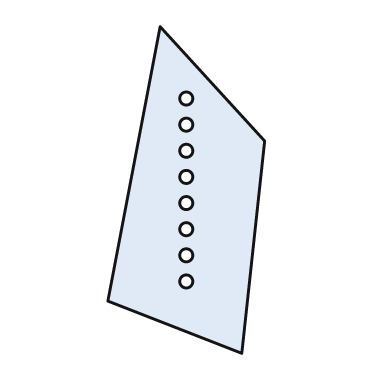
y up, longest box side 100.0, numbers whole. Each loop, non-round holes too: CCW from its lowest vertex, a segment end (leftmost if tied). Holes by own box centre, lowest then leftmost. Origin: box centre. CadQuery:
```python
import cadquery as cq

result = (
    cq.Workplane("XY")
    .moveTo(17.0, -50.0)
    .lineTo(24.0, 15.0)
    .lineTo(-8.0, 50.0)
    .lineTo(-24.0, -34.0)
    .close()
    .moveTo(0.0, -28.0)
    .circle(2.0)
    .moveTo(0.0, -20.0)
    .circle(2.0)
    .moveTo(0.0, -12.0)
    .circle(2.0)
    .moveTo(0.0, -4.0)
    .circle(2.0)
    .moveTo(0.0, 4.0)
    .circle(2.0)
    .moveTo(0.0, 12.0)
    .circle(2.0)
    .moveTo(0.0, 20.0)
    .circle(2.0)
    .moveTo(0.0, 28.0)
    .circle(2.0)
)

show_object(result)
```